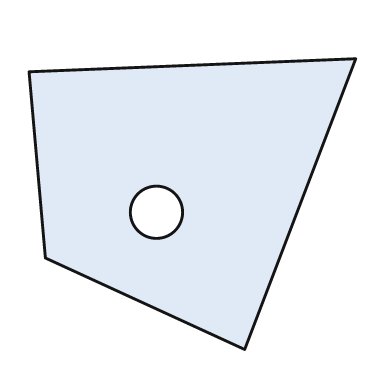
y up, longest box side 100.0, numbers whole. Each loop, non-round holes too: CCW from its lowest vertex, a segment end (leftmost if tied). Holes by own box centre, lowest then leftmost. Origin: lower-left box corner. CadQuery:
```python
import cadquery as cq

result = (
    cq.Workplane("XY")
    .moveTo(66.0, 0.0)
    .lineTo(100.0, 89.0)
    .lineTo(0.0, 85.0)
    .lineTo(5.0, 28.0)
    .close()
    .moveTo(39.0, 42.0)
    .circle(8.0)
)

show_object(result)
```